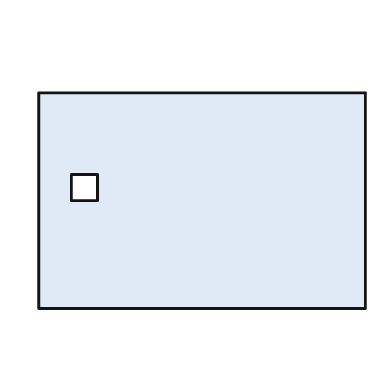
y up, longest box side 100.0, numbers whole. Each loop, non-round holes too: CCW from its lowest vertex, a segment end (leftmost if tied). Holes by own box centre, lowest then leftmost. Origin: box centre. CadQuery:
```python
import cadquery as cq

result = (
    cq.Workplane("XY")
    .moveTo(-50.0, -33.0)
    .lineTo(50.0, -33.0)
    .lineTo(50.0, 33.0)
    .lineTo(-50.0, 33.0)
    .close()
    .moveTo(-40.0, 0.0)
    .lineTo(-32.0, 0.0)
    .lineTo(-32.0, 8.0)
    .lineTo(-40.0, 8.0)
    .close()
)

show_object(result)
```